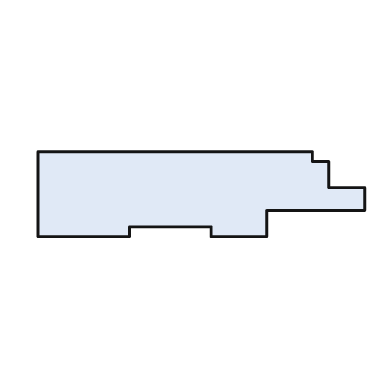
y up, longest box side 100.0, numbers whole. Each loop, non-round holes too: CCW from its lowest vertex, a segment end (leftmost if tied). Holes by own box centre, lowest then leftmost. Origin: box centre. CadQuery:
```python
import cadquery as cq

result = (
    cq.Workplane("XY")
    .moveTo(-50.0, -13.0)
    .lineTo(-22.0, -13.0)
    .lineTo(-22.0, -10.0)
    .lineTo(3.0, -10.0)
    .lineTo(3.0, -13.0)
    .lineTo(20.0, -13.0)
    .lineTo(20.0, -5.0)
    .lineTo(50.0, -5.0)
    .lineTo(50.0, 2.0)
    .lineTo(39.0, 2.0)
    .lineTo(39.0, 10.0)
    .lineTo(34.0, 10.0)
    .lineTo(34.0, 13.0)
    .lineTo(-50.0, 13.0)
    .close()
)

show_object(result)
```